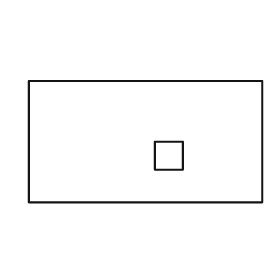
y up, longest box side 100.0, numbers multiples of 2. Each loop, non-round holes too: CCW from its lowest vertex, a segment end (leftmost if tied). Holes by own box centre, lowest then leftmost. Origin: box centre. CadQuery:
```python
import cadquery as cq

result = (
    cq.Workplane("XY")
    .moveTo(-50.0, -26.0)
    .lineTo(50.0, -26.0)
    .lineTo(50.0, 26.0)
    .lineTo(-50.0, 26.0)
    .close()
    .moveTo(4.0, -12.0)
    .lineTo(16.0, -12.0)
    .lineTo(16.0, 0.0)
    .lineTo(4.0, 0.0)
    .close()
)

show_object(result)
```